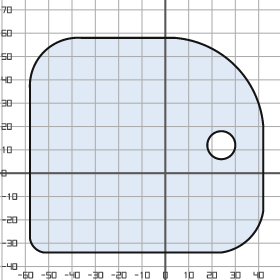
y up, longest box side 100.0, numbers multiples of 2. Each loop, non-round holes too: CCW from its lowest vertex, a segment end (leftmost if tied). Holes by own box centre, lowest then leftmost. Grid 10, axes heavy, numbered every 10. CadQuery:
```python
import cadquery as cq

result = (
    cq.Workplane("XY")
    .moveTo(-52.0, -34.0)
    .lineTo(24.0, -34.0)
    .threePointArc((36.0, -28.0), (42.0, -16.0))
    .lineTo(42.0, 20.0)
    .threePointArc((30.0, 46.0), (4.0, 58.0))
    .lineTo(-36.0, 58.0)
    .threePointArc((-52.0, 52.0), (-58.0, 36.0))
    .lineTo(-58.0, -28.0)
    .threePointArc((-56.0, -32.0), (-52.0, -34.0))
    .close()
    .moveTo(24.0, 12.0)
    .circle(6.0)
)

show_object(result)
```